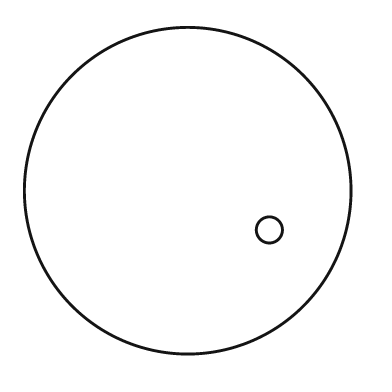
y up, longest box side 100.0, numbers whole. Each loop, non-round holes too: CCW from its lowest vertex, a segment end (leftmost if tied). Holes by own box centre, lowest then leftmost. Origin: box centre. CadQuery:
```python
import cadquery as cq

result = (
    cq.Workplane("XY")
    .moveTo(0.0, 0.0)
    .circle(50.0)
    .moveTo(25.0, -12.0)
    .circle(4.0)
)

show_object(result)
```